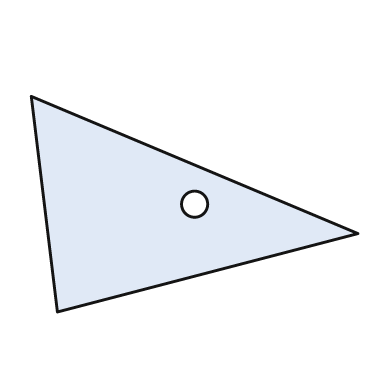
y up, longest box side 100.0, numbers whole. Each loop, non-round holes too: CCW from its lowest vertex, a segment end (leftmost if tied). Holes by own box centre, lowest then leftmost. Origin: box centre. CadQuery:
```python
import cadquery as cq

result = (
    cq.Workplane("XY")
    .moveTo(-42.0, -33.0)
    .lineTo(50.0, -9.0)
    .lineTo(-50.0, 33.0)
    .close()
    .moveTo(0.0, 0.0)
    .circle(4.0)
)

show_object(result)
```